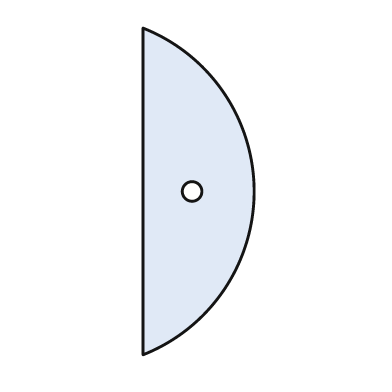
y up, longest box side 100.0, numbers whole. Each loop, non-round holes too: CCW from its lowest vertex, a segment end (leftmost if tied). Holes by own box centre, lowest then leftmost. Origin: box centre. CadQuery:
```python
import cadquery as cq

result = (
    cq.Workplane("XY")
    .moveTo(-17.0, -50.0)
    .threePointArc((17.0, 0.0), (-17.0, 50.0))
    .close()
    .moveTo(-2.0, 0.0)
    .circle(3.0)
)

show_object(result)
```